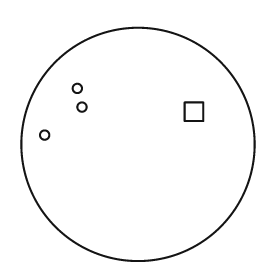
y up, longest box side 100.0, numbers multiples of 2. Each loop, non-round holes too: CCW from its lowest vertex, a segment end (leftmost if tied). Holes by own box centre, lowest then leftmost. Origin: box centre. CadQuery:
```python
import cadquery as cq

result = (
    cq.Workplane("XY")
    .moveTo(0.0, 0.0)
    .circle(50.0)
    .moveTo(-40.0, 4.0)
    .circle(2.0)
    .moveTo(20.0, 10.0)
    .lineTo(28.0, 10.0)
    .lineTo(28.0, 18.0)
    .lineTo(20.0, 18.0)
    .close()
    .moveTo(-24.0, 16.0)
    .circle(2.0)
    .moveTo(-26.0, 24.0)
    .circle(2.0)
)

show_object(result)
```